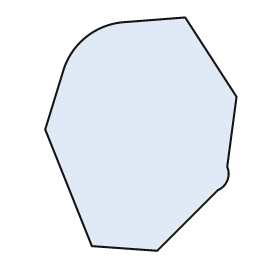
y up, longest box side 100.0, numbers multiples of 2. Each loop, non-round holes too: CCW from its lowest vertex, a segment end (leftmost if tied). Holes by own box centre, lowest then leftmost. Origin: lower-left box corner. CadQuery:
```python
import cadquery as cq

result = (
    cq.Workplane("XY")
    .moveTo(48.0, 0.0)
    .lineTo(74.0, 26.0)
    .threePointArc((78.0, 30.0), (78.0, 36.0))
    .lineTo(82.0, 66.0)
    .lineTo(60.0, 100.0)
    .lineTo(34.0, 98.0)
    .threePointArc((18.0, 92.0), (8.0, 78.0))
    .lineTo(0.0, 52.0)
    .lineTo(20.0, 2.0)
    .close()
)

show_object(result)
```